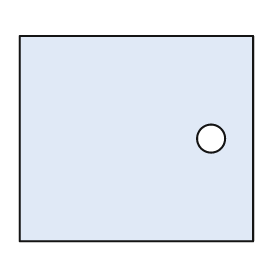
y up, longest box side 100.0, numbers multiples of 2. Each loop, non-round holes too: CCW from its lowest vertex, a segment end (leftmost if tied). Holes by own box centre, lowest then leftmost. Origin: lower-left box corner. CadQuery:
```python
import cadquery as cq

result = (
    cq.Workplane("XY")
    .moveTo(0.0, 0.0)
    .lineTo(100.0, 0.0)
    .lineTo(100.0, 88.0)
    .lineTo(0.0, 88.0)
    .close()
    .moveTo(82.0, 44.0)
    .circle(6.0)
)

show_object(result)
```